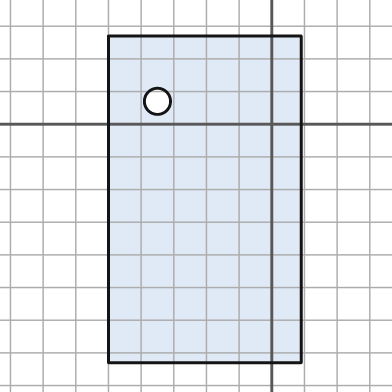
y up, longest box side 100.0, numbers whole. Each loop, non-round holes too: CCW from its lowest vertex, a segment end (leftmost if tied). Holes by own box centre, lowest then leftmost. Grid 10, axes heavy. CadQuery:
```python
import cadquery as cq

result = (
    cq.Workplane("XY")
    .moveTo(-50.0, -73.0)
    .lineTo(9.0, -73.0)
    .lineTo(9.0, 27.0)
    .lineTo(-50.0, 27.0)
    .close()
    .moveTo(-35.0, 7.0)
    .circle(4.0)
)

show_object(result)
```